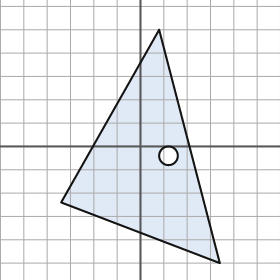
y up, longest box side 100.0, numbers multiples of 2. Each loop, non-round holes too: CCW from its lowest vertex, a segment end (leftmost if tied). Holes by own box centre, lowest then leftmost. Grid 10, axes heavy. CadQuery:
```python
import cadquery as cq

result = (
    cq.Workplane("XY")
    .moveTo(34.0, -50.0)
    .lineTo(8.0, 50.0)
    .lineTo(-34.0, -24.0)
    .close()
    .moveTo(12.0, -4.0)
    .circle(4.0)
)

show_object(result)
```